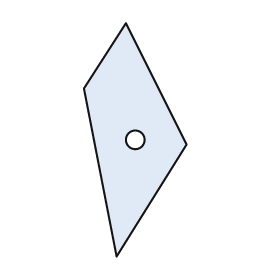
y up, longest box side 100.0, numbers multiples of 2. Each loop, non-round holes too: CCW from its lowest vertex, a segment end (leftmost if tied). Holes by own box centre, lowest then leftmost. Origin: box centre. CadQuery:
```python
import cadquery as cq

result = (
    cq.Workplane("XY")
    .moveTo(-8.0, -50.0)
    .lineTo(22.0, -2.0)
    .lineTo(-4.0, 50.0)
    .lineTo(-22.0, 22.0)
    .close()
    .moveTo(0.0, 0.0)
    .circle(4.0)
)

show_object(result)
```